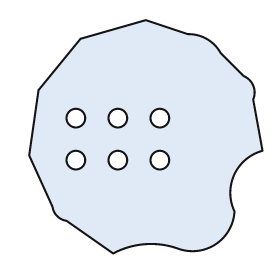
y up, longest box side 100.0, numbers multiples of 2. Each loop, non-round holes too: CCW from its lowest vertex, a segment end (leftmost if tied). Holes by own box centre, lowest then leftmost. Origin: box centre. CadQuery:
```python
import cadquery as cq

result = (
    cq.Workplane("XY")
    .moveTo(-14.0, -50.0)
    .threePointArc((0.0, -46.0), (14.0, -48.0))
    .threePointArc((30.0, -46.0), (38.0, -32.0))
    .threePointArc((38.0, -16.0), (50.0, -6.0))
    .lineTo(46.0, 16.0)
    .threePointArc((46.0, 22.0), (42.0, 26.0))
    .lineTo(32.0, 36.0)
    .threePointArc((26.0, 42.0), (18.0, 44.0))
    .lineTo(0.0, 50.0)
    .lineTo(-28.0, 42.0)
    .lineTo(-46.0, 20.0)
    .lineTo(-50.0, -8.0)
    .lineTo(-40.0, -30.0)
    .threePointArc((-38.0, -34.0), (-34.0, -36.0))
    .close()
    .moveTo(-30.0, -10.0)
    .circle(4.0)
    .moveTo(-12.0, -10.0)
    .circle(4.0)
    .moveTo(6.0, -10.0)
    .circle(4.0)
    .moveTo(-30.0, 8.0)
    .circle(4.0)
    .moveTo(-12.0, 8.0)
    .circle(4.0)
    .moveTo(6.0, 8.0)
    .circle(4.0)
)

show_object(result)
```